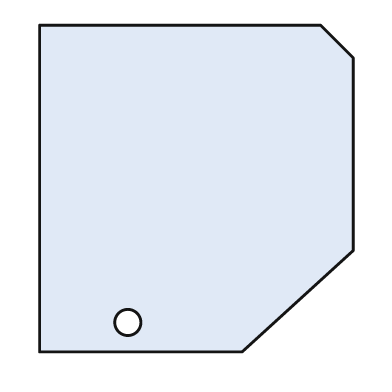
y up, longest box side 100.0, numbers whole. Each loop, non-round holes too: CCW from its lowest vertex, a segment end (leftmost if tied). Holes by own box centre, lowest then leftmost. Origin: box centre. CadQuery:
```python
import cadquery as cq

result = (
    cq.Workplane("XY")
    .moveTo(-48.0, -50.0)
    .lineTo(14.0, -50.0)
    .lineTo(48.0, -19.0)
    .lineTo(48.0, 40.0)
    .lineTo(38.0, 50.0)
    .lineTo(-48.0, 50.0)
    .close()
    .moveTo(-21.0, -41.0)
    .circle(4.0)
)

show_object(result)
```